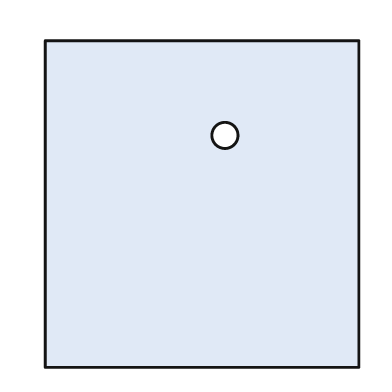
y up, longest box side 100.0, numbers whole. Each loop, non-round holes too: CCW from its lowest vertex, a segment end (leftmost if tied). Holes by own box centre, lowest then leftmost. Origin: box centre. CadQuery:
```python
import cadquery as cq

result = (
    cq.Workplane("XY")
    .moveTo(-48.0, -50.0)
    .lineTo(48.0, -50.0)
    .lineTo(48.0, 50.0)
    .lineTo(-48.0, 50.0)
    .close()
    .moveTo(7.0, 21.0)
    .circle(4.0)
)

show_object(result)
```